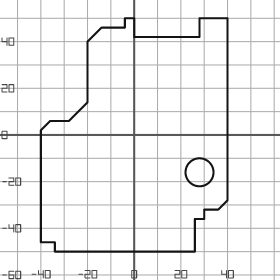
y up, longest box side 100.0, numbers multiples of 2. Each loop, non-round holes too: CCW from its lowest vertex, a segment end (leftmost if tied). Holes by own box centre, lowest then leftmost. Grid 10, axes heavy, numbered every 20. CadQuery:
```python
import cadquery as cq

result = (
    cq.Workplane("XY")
    .moveTo(-34.0, -50.0)
    .lineTo(26.0, -50.0)
    .lineTo(26.0, -36.0)
    .lineTo(30.0, -36.0)
    .lineTo(30.0, -32.0)
    .lineTo(36.0, -32.0)
    .lineTo(40.0, -28.0)
    .lineTo(40.0, 50.0)
    .lineTo(28.0, 50.0)
    .lineTo(28.0, 42.0)
    .lineTo(0.0, 42.0)
    .lineTo(0.0, 50.0)
    .lineTo(-4.0, 50.0)
    .lineTo(-4.0, 46.0)
    .lineTo(-14.0, 46.0)
    .lineTo(-20.0, 40.0)
    .lineTo(-20.0, 14.0)
    .lineTo(-28.0, 6.0)
    .lineTo(-36.0, 6.0)
    .lineTo(-40.0, 2.0)
    .lineTo(-40.0, -46.0)
    .lineTo(-34.0, -46.0)
    .close()
    .moveTo(28.0, -16.0)
    .circle(6.0)
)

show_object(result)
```